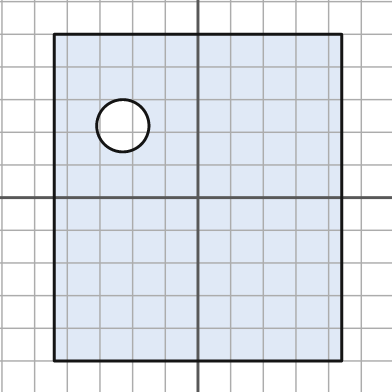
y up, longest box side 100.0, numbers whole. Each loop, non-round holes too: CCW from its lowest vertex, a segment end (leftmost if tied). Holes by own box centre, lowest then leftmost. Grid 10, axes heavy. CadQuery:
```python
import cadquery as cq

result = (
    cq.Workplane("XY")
    .moveTo(-44.0, -50.0)
    .lineTo(44.0, -50.0)
    .lineTo(44.0, 50.0)
    .lineTo(-44.0, 50.0)
    .close()
    .moveTo(-23.0, 22.0)
    .circle(8.0)
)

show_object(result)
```